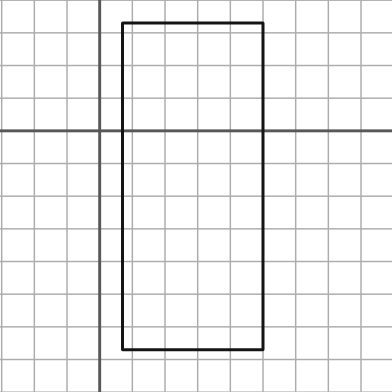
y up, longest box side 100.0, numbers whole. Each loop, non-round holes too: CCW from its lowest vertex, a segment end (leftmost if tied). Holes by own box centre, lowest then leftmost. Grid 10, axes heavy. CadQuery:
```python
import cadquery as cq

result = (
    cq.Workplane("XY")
    .moveTo(7.0, -67.0)
    .lineTo(50.0, -67.0)
    .lineTo(50.0, 33.0)
    .lineTo(7.0, 33.0)
    .close()
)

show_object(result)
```